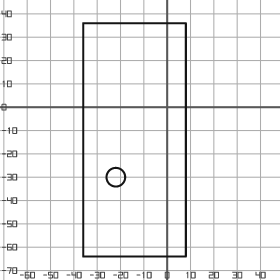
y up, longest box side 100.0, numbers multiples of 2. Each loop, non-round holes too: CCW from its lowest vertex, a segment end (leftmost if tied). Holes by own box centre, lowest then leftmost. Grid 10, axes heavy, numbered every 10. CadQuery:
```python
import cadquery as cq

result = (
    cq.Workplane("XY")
    .moveTo(-36.0, -64.0)
    .lineTo(8.0, -64.0)
    .lineTo(8.0, 36.0)
    .lineTo(-36.0, 36.0)
    .close()
    .moveTo(-22.0, -30.0)
    .circle(4.0)
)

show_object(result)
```